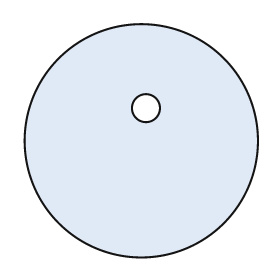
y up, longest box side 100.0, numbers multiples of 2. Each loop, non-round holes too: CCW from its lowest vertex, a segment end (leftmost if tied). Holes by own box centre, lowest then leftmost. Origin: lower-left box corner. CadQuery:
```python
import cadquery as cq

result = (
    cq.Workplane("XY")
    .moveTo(50.0, 50.0)
    .circle(50.0)
    .moveTo(52.0, 64.0)
    .circle(6.0)
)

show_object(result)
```